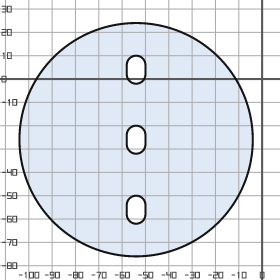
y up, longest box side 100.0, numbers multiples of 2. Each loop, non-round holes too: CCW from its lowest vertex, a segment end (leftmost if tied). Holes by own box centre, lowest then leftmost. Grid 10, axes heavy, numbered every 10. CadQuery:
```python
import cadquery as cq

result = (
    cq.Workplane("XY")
    .moveTo(-54.0, -26.0)
    .circle(50.0)
    .moveTo(-58.0, -58.0)
    .threePointArc((-54.0, -62.0), (-50.0, -58.0))
    .lineTo(-50.0, -54.0)
    .threePointArc((-54.0, -50.0), (-58.0, -54.0))
    .close()
    .moveTo(-58.0, -28.0)
    .threePointArc((-54.0, -32.0), (-50.0, -28.0))
    .lineTo(-50.0, -24.0)
    .threePointArc((-54.0, -20.0), (-58.0, -24.0))
    .close()
    .moveTo(-58.0, 2.0)
    .threePointArc((-54.0, -2.0), (-50.0, 2.0))
    .lineTo(-50.0, 6.0)
    .threePointArc((-54.0, 10.0), (-58.0, 6.0))
    .close()
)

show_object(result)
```